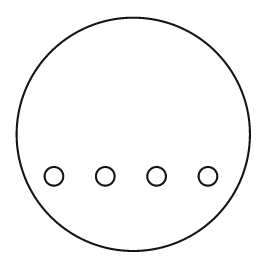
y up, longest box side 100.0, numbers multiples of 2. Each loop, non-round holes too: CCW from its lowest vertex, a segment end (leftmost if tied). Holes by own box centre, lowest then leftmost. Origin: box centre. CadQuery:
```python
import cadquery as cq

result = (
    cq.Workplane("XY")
    .moveTo(0.0, 0.0)
    .circle(50.0)
    .moveTo(-34.0, -18.0)
    .circle(4.0)
    .moveTo(-12.0, -18.0)
    .circle(4.0)
    .moveTo(10.0, -18.0)
    .circle(4.0)
    .moveTo(32.0, -18.0)
    .circle(4.0)
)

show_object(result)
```